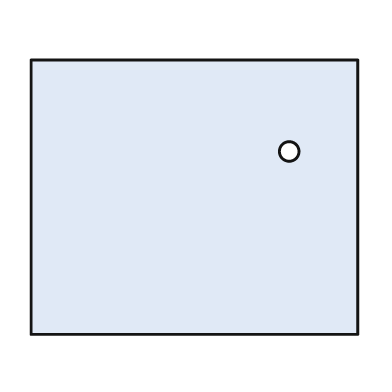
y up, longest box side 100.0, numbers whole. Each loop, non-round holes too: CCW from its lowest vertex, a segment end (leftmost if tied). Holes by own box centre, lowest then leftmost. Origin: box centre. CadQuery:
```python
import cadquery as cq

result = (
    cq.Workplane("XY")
    .moveTo(-50.0, -42.0)
    .lineTo(50.0, -42.0)
    .lineTo(50.0, 42.0)
    .lineTo(-50.0, 42.0)
    .close()
    .moveTo(29.0, 14.0)
    .circle(3.0)
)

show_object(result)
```